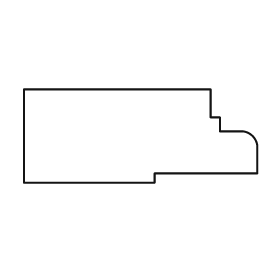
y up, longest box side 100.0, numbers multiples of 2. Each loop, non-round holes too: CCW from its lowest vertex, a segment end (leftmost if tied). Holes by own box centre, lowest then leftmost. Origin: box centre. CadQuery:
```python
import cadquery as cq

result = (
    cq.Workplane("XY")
    .moveTo(-50.0, -20.0)
    .lineTo(6.0, -20.0)
    .lineTo(6.0, -16.0)
    .lineTo(50.0, -16.0)
    .lineTo(50.0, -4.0)
    .threePointArc((48.0, 0.0), (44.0, 2.0))
    .lineTo(34.0, 2.0)
    .lineTo(34.0, 8.0)
    .lineTo(30.0, 8.0)
    .lineTo(30.0, 20.0)
    .lineTo(-50.0, 20.0)
    .close()
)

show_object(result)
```